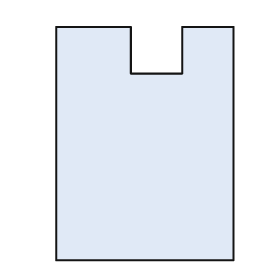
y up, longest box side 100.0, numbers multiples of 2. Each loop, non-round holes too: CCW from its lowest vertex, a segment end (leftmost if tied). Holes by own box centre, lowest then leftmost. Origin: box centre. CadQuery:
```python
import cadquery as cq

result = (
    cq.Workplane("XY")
    .moveTo(-38.0, -50.0)
    .lineTo(38.0, -50.0)
    .lineTo(38.0, 50.0)
    .lineTo(16.0, 50.0)
    .lineTo(16.0, 30.0)
    .lineTo(-6.0, 30.0)
    .lineTo(-6.0, 50.0)
    .lineTo(-38.0, 50.0)
    .close()
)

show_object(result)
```